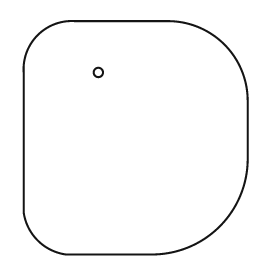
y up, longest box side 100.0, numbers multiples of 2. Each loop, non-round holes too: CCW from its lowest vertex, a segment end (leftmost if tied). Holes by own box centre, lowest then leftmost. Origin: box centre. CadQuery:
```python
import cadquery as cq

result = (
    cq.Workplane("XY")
    .moveTo(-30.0, -50.0)
    .lineTo(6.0, -50.0)
    .threePointArc((36.0, -38.0), (48.0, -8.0))
    .lineTo(48.0, 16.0)
    .threePointArc((38.0, 40.0), (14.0, 50.0))
    .lineTo(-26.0, 50.0)
    .threePointArc((-42.0, 44.0), (-48.0, 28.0))
    .lineTo(-48.0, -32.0)
    .threePointArc((-42.0, -44.0), (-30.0, -50.0))
    .close()
    .moveTo(-16.0, 28.0)
    .circle(2.0)
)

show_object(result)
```